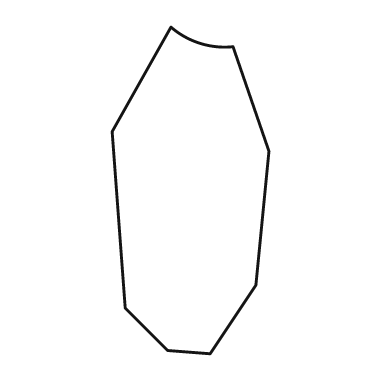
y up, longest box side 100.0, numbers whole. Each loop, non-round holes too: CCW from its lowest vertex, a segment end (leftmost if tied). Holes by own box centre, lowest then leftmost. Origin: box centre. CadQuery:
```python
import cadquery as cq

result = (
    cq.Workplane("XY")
    .moveTo(6.0, -50.0)
    .lineTo(20.0, -29.0)
    .lineTo(24.0, 12.0)
    .lineTo(13.0, 44.0)
    .threePointArc((3.0, 45.0), (-6.0, 50.0))
    .lineTo(-24.0, 18.0)
    .lineTo(-20.0, -36.0)
    .lineTo(-7.0, -49.0)
    .close()
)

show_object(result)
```